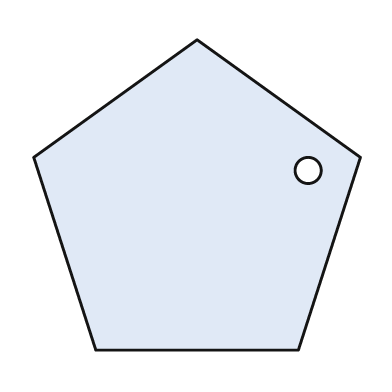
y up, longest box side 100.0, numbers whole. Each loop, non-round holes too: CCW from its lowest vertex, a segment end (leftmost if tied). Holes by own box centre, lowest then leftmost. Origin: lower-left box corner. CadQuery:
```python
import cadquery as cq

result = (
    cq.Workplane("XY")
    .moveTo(19.0, 0.0)
    .lineTo(81.0, 0.0)
    .lineTo(100.0, 59.0)
    .lineTo(50.0, 95.0)
    .lineTo(0.0, 59.0)
    .close()
    .moveTo(84.0, 55.0)
    .circle(4.0)
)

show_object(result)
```